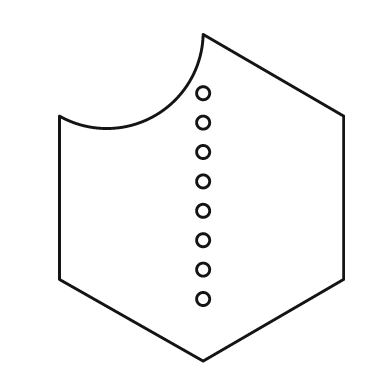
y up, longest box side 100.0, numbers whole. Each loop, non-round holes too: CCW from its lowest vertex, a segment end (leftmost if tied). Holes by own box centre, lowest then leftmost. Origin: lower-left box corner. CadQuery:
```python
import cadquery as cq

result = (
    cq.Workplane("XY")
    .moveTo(44.0, 0.0)
    .lineTo(87.0, 25.0)
    .lineTo(87.0, 75.0)
    .lineTo(44.0, 100.0)
    .threePointArc((29.0, 75.0), (0.0, 75.0))
    .lineTo(0.0, 25.0)
    .close()
    .moveTo(44.0, 19.0)
    .circle(2.0)
    .moveTo(44.0, 28.0)
    .circle(2.0)
    .moveTo(44.0, 37.0)
    .circle(2.0)
    .moveTo(44.0, 46.0)
    .circle(2.0)
    .moveTo(44.0, 55.0)
    .circle(2.0)
    .moveTo(44.0, 64.0)
    .circle(2.0)
    .moveTo(44.0, 73.0)
    .circle(2.0)
    .moveTo(44.0, 82.0)
    .circle(2.0)
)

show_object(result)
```